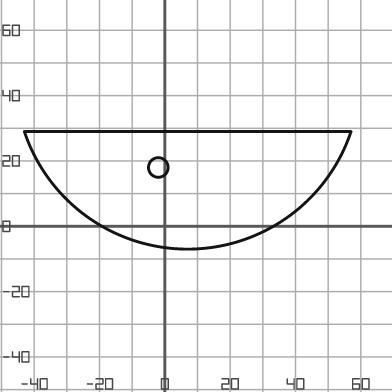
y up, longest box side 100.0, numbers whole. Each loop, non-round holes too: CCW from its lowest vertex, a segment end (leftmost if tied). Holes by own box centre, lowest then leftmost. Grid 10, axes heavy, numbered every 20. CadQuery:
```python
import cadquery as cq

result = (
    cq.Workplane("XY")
    .moveTo(-43.0, 29.0)
    .threePointArc((7.0, -7.0), (57.0, 29.0))
    .close()
    .moveTo(-2.0, 18.0)
    .circle(3.0)
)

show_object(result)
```